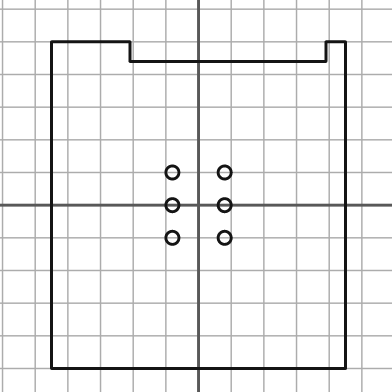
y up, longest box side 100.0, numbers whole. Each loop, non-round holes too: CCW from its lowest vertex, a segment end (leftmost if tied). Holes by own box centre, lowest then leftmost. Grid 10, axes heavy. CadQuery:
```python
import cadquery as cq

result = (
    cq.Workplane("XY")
    .moveTo(-45.0, -50.0)
    .lineTo(45.0, -50.0)
    .lineTo(45.0, 50.0)
    .lineTo(39.0, 50.0)
    .lineTo(39.0, 44.0)
    .lineTo(-21.0, 44.0)
    .lineTo(-21.0, 50.0)
    .lineTo(-45.0, 50.0)
    .close()
    .moveTo(-8.0, -10.0)
    .circle(2.0)
    .moveTo(8.0, -10.0)
    .circle(2.0)
    .moveTo(-8.0, 0.0)
    .circle(2.0)
    .moveTo(8.0, 0.0)
    .circle(2.0)
    .moveTo(-8.0, 10.0)
    .circle(2.0)
    .moveTo(8.0, 10.0)
    .circle(2.0)
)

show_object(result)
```